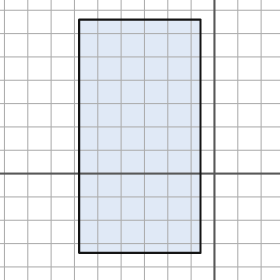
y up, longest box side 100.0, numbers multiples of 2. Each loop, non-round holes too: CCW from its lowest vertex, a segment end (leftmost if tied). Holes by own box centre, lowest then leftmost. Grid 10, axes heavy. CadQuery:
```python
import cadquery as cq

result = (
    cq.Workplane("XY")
    .moveTo(-58.0, -34.0)
    .lineTo(-6.0, -34.0)
    .lineTo(-6.0, 66.0)
    .lineTo(-58.0, 66.0)
    .close()
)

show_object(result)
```